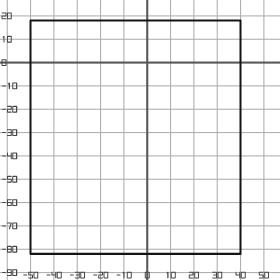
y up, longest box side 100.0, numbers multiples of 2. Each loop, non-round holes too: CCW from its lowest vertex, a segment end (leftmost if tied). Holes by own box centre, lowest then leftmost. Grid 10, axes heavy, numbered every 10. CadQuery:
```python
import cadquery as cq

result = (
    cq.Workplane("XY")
    .moveTo(-50.0, -82.0)
    .lineTo(40.0, -82.0)
    .lineTo(40.0, 18.0)
    .lineTo(-50.0, 18.0)
    .close()
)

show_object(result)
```